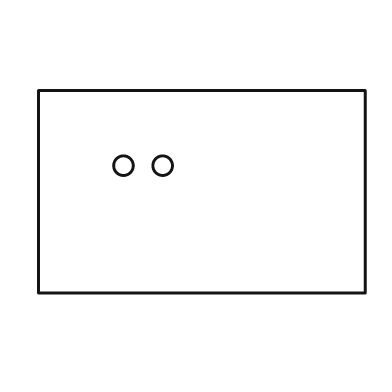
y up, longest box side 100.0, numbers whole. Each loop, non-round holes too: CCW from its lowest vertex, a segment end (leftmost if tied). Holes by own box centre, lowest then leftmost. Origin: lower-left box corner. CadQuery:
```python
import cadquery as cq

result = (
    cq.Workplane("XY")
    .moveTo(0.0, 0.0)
    .lineTo(100.0, 0.0)
    .lineTo(100.0, 62.0)
    .lineTo(0.0, 62.0)
    .close()
    .moveTo(26.0, 39.0)
    .circle(3.0)
    .moveTo(38.0, 39.0)
    .circle(3.0)
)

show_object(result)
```